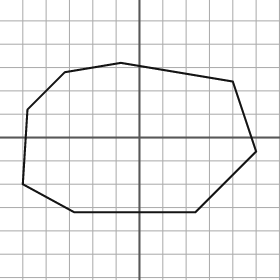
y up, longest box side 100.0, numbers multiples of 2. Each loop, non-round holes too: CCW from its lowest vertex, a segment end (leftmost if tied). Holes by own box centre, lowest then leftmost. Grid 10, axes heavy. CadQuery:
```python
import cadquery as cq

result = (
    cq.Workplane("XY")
    .moveTo(-28.0, -32.0)
    .lineTo(24.0, -32.0)
    .lineTo(50.0, -6.0)
    .lineTo(40.0, 24.0)
    .lineTo(-8.0, 32.0)
    .lineTo(-32.0, 28.0)
    .lineTo(-48.0, 12.0)
    .lineTo(-50.0, -20.0)
    .close()
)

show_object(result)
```